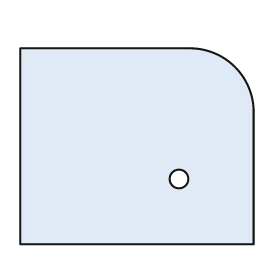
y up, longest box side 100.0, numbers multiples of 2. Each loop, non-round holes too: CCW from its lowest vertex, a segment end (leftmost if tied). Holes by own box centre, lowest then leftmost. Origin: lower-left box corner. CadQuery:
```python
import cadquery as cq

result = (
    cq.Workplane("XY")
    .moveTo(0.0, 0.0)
    .lineTo(100.0, 0.0)
    .lineTo(100.0, 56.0)
    .threePointArc((92.0, 76.0), (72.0, 84.0))
    .lineTo(0.0, 84.0)
    .close()
    .moveTo(68.0, 28.0)
    .circle(4.0)
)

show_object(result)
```